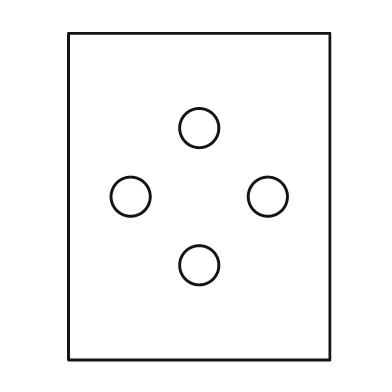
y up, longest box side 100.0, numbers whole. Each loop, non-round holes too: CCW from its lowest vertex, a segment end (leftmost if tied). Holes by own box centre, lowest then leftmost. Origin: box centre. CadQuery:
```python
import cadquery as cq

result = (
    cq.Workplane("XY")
    .moveTo(-40.0, -50.0)
    .lineTo(40.0, -50.0)
    .lineTo(40.0, 50.0)
    .lineTo(-40.0, 50.0)
    .close()
    .moveTo(0.0, -21.0)
    .circle(6.0)
    .moveTo(-21.0, 0.0)
    .circle(6.0)
    .moveTo(21.0, 0.0)
    .circle(6.0)
    .moveTo(0.0, 21.0)
    .circle(6.0)
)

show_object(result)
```